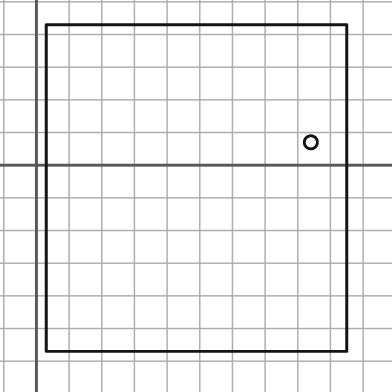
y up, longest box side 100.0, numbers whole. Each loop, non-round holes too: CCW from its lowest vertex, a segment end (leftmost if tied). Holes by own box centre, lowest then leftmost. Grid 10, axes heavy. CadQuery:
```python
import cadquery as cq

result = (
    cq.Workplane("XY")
    .moveTo(3.0, -57.0)
    .lineTo(95.0, -57.0)
    .lineTo(95.0, 43.0)
    .lineTo(3.0, 43.0)
    .close()
    .moveTo(84.0, 7.0)
    .circle(2.0)
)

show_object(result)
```